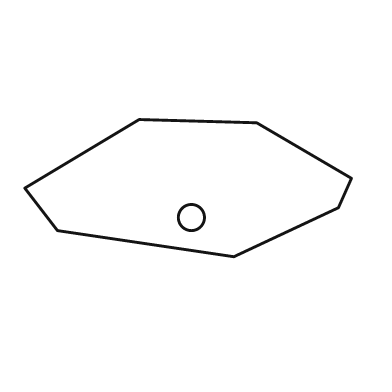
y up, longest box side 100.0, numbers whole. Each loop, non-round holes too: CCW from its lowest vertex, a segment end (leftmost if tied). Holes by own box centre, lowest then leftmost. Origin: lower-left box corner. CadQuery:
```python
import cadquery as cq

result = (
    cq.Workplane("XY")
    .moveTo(64.0, 0.0)
    .lineTo(96.0, 15.0)
    .lineTo(100.0, 24.0)
    .lineTo(71.0, 41.0)
    .lineTo(35.0, 42.0)
    .lineTo(0.0, 21.0)
    .lineTo(10.0, 8.0)
    .close()
    .moveTo(51.0, 12.0)
    .circle(4.0)
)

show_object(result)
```